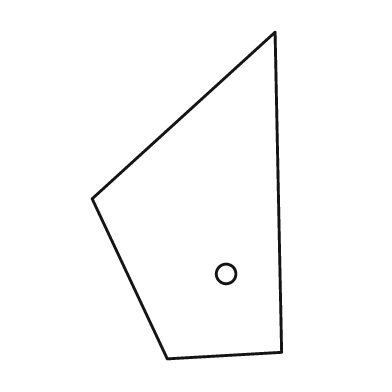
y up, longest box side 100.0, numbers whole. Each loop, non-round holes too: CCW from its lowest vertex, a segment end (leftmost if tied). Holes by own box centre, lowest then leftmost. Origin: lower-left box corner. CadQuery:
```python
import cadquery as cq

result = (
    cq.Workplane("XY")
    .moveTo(23.0, 0.0)
    .lineTo(58.0, 2.0)
    .lineTo(56.0, 100.0)
    .lineTo(0.0, 49.0)
    .close()
    .moveTo(41.0, 26.0)
    .circle(3.0)
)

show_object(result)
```